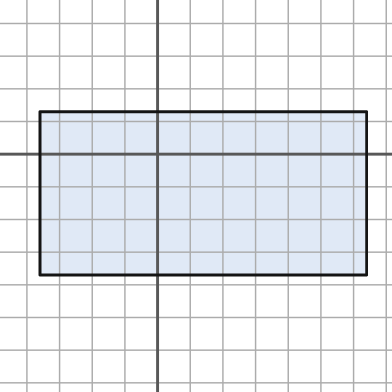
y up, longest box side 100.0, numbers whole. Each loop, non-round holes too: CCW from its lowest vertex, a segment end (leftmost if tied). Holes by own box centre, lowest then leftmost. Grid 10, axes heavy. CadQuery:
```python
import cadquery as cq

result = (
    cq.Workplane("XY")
    .moveTo(-36.0, -37.0)
    .lineTo(64.0, -37.0)
    .lineTo(64.0, 13.0)
    .lineTo(-36.0, 13.0)
    .close()
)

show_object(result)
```